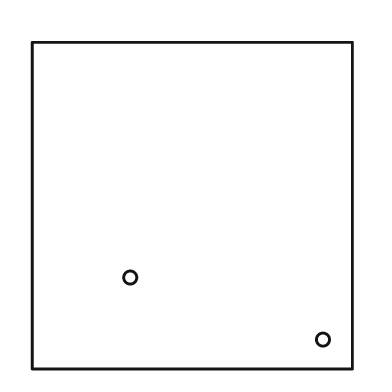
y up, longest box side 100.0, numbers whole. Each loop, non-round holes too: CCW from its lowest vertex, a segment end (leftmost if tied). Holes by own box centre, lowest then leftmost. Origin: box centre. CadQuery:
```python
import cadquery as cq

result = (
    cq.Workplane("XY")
    .moveTo(-49.0, -50.0)
    .lineTo(49.0, -50.0)
    .lineTo(49.0, 50.0)
    .lineTo(-49.0, 50.0)
    .close()
    .moveTo(40.0, -41.0)
    .circle(2.0)
    .moveTo(-19.0, -22.0)
    .circle(2.0)
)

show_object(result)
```